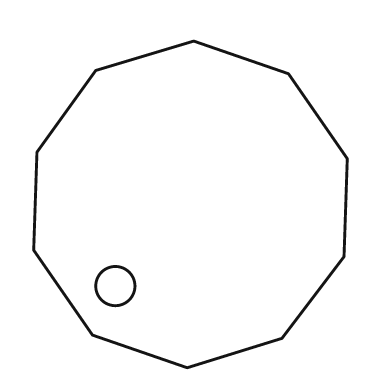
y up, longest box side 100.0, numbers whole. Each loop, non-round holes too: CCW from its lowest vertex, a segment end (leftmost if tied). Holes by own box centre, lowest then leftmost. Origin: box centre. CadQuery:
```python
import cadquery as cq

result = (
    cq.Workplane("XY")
    .moveTo(-1.0, -50.0)
    .lineTo(28.0, -41.0)
    .lineTo(47.0, -16.0)
    .lineTo(48.0, 14.0)
    .lineTo(30.0, 40.0)
    .lineTo(1.0, 50.0)
    .lineTo(-29.0, 41.0)
    .lineTo(-47.0, 16.0)
    .lineTo(-48.0, -14.0)
    .lineTo(-30.0, -40.0)
    .close()
    .moveTo(-23.0, -25.0)
    .circle(6.0)
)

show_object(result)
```